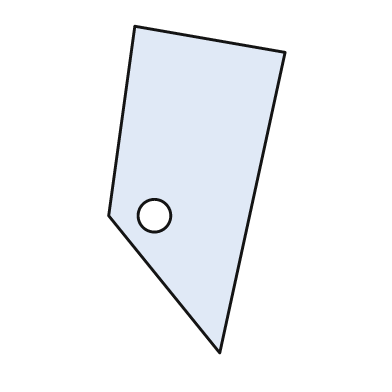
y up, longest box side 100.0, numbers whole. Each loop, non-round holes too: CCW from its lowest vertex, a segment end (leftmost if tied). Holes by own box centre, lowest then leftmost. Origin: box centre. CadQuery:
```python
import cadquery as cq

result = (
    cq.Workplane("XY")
    .moveTo(7.0, -50.0)
    .lineTo(27.0, 42.0)
    .lineTo(-19.0, 50.0)
    .lineTo(-27.0, -8.0)
    .close()
    .moveTo(-13.0, -8.0)
    .circle(5.0)
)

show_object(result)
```